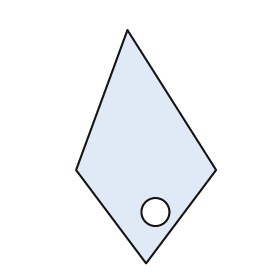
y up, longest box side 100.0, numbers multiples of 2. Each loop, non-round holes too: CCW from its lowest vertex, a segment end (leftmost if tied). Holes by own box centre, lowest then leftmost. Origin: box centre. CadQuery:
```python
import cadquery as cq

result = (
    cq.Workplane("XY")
    .moveTo(0.0, -50.0)
    .lineTo(30.0, -10.0)
    .lineTo(-8.0, 50.0)
    .lineTo(-30.0, -10.0)
    .close()
    .moveTo(4.0, -28.0)
    .circle(6.0)
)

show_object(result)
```